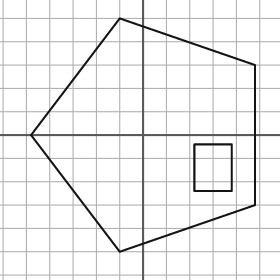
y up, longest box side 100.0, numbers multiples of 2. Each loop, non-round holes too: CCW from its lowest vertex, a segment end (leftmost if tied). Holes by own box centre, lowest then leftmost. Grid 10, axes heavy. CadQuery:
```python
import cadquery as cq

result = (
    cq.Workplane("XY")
    .moveTo(-10.0, -50.0)
    .lineTo(48.0, -30.0)
    .lineTo(48.0, 30.0)
    .lineTo(-10.0, 50.0)
    .lineTo(-48.0, 0.0)
    .close()
    .moveTo(22.0, -24.0)
    .lineTo(38.0, -24.0)
    .lineTo(38.0, -4.0)
    .lineTo(22.0, -4.0)
    .close()
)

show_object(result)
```